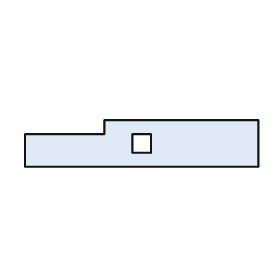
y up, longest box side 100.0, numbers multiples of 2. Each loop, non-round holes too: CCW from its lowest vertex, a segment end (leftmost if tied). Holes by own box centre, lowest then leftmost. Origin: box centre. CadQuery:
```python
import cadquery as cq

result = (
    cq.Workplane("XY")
    .moveTo(-50.0, -10.0)
    .lineTo(50.0, -10.0)
    .lineTo(50.0, 10.0)
    .lineTo(-16.0, 10.0)
    .lineTo(-16.0, 4.0)
    .lineTo(-50.0, 4.0)
    .close()
    .moveTo(-4.0, -4.0)
    .lineTo(4.0, -4.0)
    .lineTo(4.0, 4.0)
    .lineTo(-4.0, 4.0)
    .close()
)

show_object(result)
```